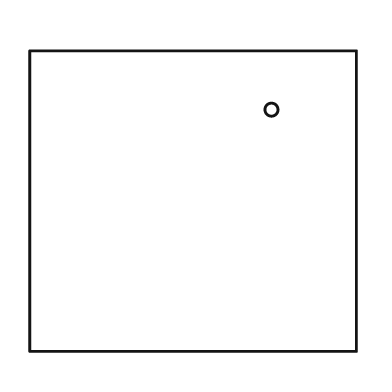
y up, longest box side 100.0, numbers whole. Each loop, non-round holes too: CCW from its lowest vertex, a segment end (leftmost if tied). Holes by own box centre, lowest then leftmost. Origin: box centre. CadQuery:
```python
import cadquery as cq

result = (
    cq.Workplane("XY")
    .moveTo(-50.0, -46.0)
    .lineTo(50.0, -46.0)
    .lineTo(50.0, 46.0)
    .lineTo(-50.0, 46.0)
    .close()
    .moveTo(24.0, 28.0)
    .circle(2.0)
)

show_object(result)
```